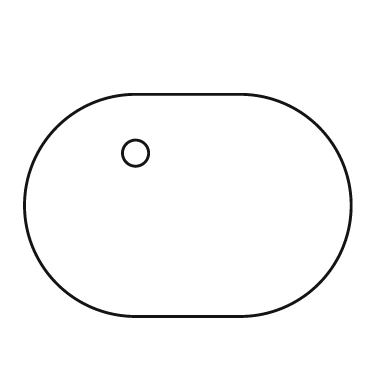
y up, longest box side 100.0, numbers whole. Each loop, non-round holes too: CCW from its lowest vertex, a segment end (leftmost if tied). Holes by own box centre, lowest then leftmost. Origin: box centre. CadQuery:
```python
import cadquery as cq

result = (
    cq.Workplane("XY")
    .moveTo(-16.0, -34.0)
    .lineTo(16.0, -34.0)
    .threePointArc((50.0, 0.0), (16.0, 34.0))
    .lineTo(-16.0, 34.0)
    .threePointArc((-50.0, 0.0), (-16.0, -34.0))
    .close()
    .moveTo(-16.0, 16.0)
    .circle(4.0)
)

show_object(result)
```